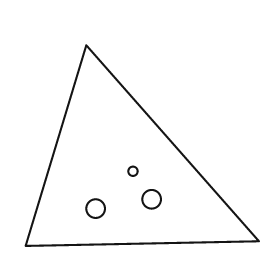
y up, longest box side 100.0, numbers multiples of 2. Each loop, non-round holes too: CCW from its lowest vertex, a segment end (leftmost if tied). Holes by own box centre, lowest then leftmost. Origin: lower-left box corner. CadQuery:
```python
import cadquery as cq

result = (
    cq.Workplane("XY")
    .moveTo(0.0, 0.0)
    .lineTo(100.0, 2.0)
    .lineTo(26.0, 86.0)
    .close()
    .moveTo(30.0, 16.0)
    .circle(4.0)
    .moveTo(54.0, 20.0)
    .circle(4.0)
    .moveTo(46.0, 32.0)
    .circle(2.0)
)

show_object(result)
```